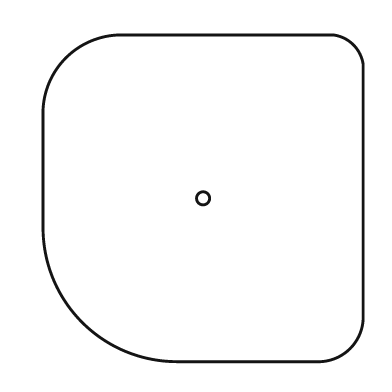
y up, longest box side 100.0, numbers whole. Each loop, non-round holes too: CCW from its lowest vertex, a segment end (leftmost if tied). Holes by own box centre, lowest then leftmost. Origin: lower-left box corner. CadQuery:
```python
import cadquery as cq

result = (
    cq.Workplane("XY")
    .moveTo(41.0, 0.0)
    .lineTo(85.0, 0.0)
    .threePointArc((94.0, 4.0), (98.0, 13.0))
    .lineTo(98.0, 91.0)
    .threePointArc((95.0, 97.0), (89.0, 100.0))
    .lineTo(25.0, 100.0)
    .threePointArc((7.0, 93.0), (0.0, 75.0))
    .lineTo(0.0, 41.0)
    .threePointArc((12.0, 12.0), (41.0, 0.0))
    .close()
    .moveTo(49.0, 50.0)
    .circle(2.0)
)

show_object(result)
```